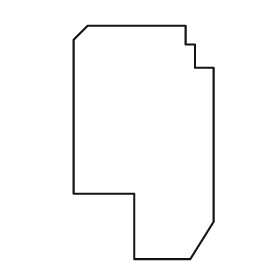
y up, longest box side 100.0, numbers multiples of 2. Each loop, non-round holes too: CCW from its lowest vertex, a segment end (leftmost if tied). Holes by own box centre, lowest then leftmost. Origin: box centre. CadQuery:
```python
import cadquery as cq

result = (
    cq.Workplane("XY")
    .moveTo(-4.0, -50.0)
    .lineTo(20.0, -50.0)
    .lineTo(30.0, -34.0)
    .lineTo(30.0, 32.0)
    .lineTo(22.0, 32.0)
    .lineTo(22.0, 42.0)
    .lineTo(18.0, 42.0)
    .lineTo(18.0, 50.0)
    .lineTo(-24.0, 50.0)
    .lineTo(-30.0, 44.0)
    .lineTo(-30.0, -22.0)
    .lineTo(-4.0, -22.0)
    .close()
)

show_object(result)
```